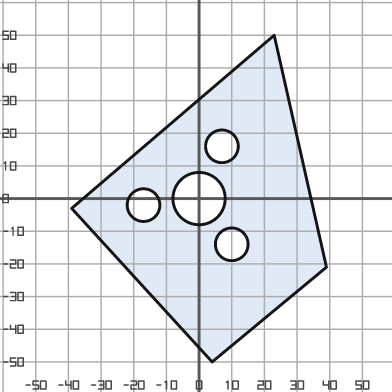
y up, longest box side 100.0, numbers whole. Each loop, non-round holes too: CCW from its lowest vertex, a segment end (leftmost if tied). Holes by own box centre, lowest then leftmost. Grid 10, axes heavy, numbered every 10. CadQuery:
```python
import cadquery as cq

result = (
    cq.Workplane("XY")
    .moveTo(4.0, -50.0)
    .lineTo(39.0, -21.0)
    .lineTo(23.0, 50.0)
    .lineTo(-39.0, -3.0)
    .close()
    .moveTo(10.0, -14.0)
    .circle(5.0)
    .moveTo(-17.0, -2.0)
    .circle(5.0)
    .moveTo(0.0, 0.0)
    .circle(8.0)
    .moveTo(7.0, 16.0)
    .circle(5.0)
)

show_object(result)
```